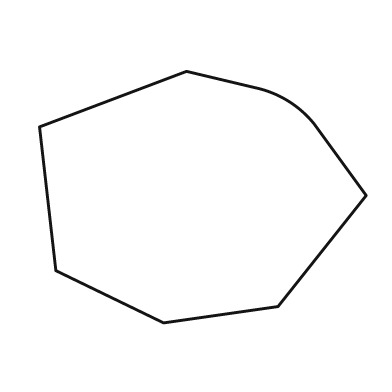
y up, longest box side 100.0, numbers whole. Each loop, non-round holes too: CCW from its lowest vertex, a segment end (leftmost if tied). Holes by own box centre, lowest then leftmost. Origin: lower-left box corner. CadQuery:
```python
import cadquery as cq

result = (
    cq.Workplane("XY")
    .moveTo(38.0, 0.0)
    .lineTo(73.0, 5.0)
    .lineTo(100.0, 39.0)
    .lineTo(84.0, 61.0)
    .threePointArc((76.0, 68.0), (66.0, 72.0))
    .lineTo(45.0, 77.0)
    .lineTo(0.0, 60.0)
    .lineTo(5.0, 16.0)
    .close()
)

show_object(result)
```